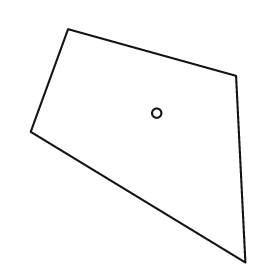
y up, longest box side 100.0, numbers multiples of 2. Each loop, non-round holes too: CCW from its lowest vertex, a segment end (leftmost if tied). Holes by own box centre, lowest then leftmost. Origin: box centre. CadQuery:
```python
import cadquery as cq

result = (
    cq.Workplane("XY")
    .moveTo(46.0, -50.0)
    .lineTo(42.0, 30.0)
    .lineTo(-30.0, 50.0)
    .lineTo(-46.0, 6.0)
    .close()
    .moveTo(8.0, 14.0)
    .circle(2.0)
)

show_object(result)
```